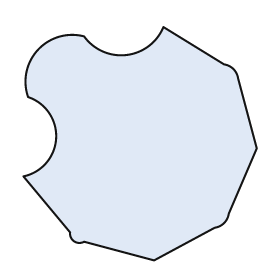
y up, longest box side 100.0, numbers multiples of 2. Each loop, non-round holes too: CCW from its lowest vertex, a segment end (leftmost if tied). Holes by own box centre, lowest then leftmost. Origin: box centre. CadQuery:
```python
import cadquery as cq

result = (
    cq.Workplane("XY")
    .moveTo(6.0, -50.0)
    .lineTo(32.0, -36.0)
    .threePointArc((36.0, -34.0), (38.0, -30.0))
    .lineTo(50.0, -2.0)
    .lineTo(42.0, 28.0)
    .threePointArc((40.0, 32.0), (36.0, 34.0))
    .lineTo(10.0, 50.0)
    .threePointArc((-6.0, 38.0), (-24.0, 46.0))
    .threePointArc((-44.0, 40.0), (-48.0, 20.0))
    .threePointArc((-36.0, 2.0), (-50.0, -14.0))
    .lineTo(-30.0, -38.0)
    .threePointArc((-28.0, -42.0), (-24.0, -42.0))
    .close()
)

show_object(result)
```